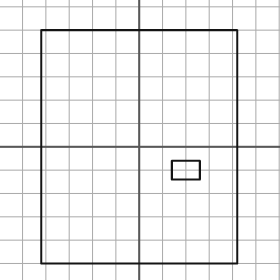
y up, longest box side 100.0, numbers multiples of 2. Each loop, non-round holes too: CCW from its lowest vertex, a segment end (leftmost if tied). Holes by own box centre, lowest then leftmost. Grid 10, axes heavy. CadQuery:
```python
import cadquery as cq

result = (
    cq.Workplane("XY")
    .moveTo(-42.0, -50.0)
    .lineTo(42.0, -50.0)
    .lineTo(42.0, 50.0)
    .lineTo(-42.0, 50.0)
    .close()
    .moveTo(14.0, -14.0)
    .lineTo(26.0, -14.0)
    .lineTo(26.0, -6.0)
    .lineTo(14.0, -6.0)
    .close()
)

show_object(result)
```